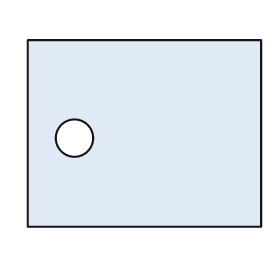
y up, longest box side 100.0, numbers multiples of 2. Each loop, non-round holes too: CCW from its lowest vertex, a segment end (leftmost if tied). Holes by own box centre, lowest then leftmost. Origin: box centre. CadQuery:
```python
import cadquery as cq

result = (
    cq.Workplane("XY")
    .moveTo(-50.0, -40.0)
    .lineTo(50.0, -40.0)
    .lineTo(50.0, 40.0)
    .lineTo(-50.0, 40.0)
    .close()
    .moveTo(-30.0, -2.0)
    .circle(8.0)
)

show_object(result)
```